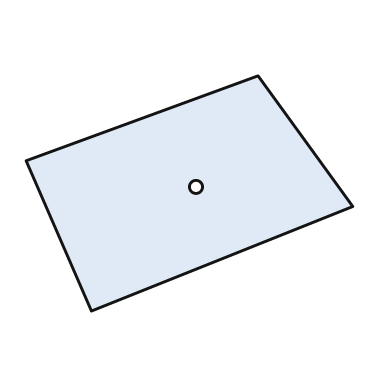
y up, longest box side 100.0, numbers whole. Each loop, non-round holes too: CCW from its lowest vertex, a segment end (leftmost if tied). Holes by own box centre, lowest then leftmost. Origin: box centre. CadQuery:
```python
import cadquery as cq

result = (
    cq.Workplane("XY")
    .moveTo(-30.0, -36.0)
    .lineTo(50.0, -4.0)
    .lineTo(21.0, 36.0)
    .lineTo(-50.0, 10.0)
    .close()
    .moveTo(2.0, 2.0)
    .circle(2.0)
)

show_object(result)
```